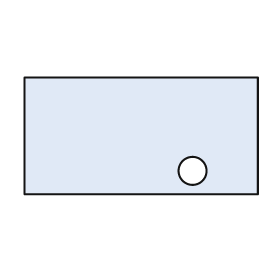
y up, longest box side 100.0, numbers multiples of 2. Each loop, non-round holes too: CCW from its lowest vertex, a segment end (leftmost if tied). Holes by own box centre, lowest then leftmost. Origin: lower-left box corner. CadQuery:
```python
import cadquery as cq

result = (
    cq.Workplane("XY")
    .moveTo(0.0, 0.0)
    .lineTo(100.0, 0.0)
    .lineTo(100.0, 50.0)
    .lineTo(0.0, 50.0)
    .close()
    .moveTo(72.0, 10.0)
    .circle(6.0)
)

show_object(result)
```